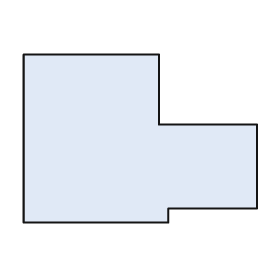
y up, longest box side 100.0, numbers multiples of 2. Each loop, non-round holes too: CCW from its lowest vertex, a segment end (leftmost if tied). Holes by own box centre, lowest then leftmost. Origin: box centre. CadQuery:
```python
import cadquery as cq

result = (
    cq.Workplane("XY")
    .moveTo(-50.0, -36.0)
    .lineTo(12.0, -36.0)
    .lineTo(12.0, -30.0)
    .lineTo(50.0, -30.0)
    .lineTo(50.0, 6.0)
    .lineTo(8.0, 6.0)
    .lineTo(8.0, 36.0)
    .lineTo(-50.0, 36.0)
    .close()
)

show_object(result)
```